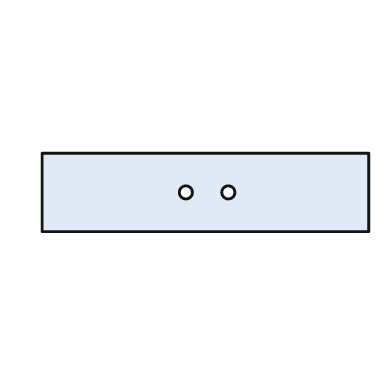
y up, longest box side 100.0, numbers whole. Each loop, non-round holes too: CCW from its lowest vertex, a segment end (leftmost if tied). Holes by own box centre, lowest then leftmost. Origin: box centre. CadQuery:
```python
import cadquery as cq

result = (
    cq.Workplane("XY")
    .moveTo(-50.0, -12.0)
    .lineTo(50.0, -12.0)
    .lineTo(50.0, 12.0)
    .lineTo(-50.0, 12.0)
    .close()
    .moveTo(-6.0, 0.0)
    .circle(2.0)
    .moveTo(7.0, 0.0)
    .circle(2.0)
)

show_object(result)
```